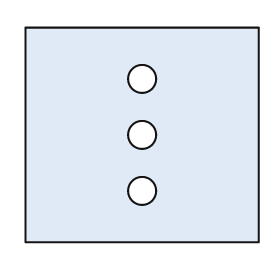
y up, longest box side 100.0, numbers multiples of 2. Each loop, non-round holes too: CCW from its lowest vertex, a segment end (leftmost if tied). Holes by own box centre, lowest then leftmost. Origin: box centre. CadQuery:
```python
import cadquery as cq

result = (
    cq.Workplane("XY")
    .moveTo(-50.0, -46.0)
    .lineTo(50.0, -46.0)
    .lineTo(50.0, 46.0)
    .lineTo(-50.0, 46.0)
    .close()
    .moveTo(0.0, -24.0)
    .circle(6.0)
    .moveTo(0.0, 0.0)
    .circle(6.0)
    .moveTo(0.0, 24.0)
    .circle(6.0)
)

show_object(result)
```